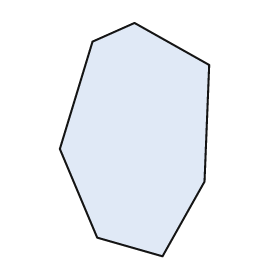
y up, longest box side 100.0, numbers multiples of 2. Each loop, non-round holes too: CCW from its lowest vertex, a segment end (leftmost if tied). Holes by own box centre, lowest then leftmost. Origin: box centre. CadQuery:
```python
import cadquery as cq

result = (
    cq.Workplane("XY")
    .moveTo(12.0, -50.0)
    .lineTo(30.0, -18.0)
    .lineTo(32.0, 32.0)
    .lineTo(0.0, 50.0)
    .lineTo(-18.0, 42.0)
    .lineTo(-32.0, -4.0)
    .lineTo(-16.0, -42.0)
    .close()
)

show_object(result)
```